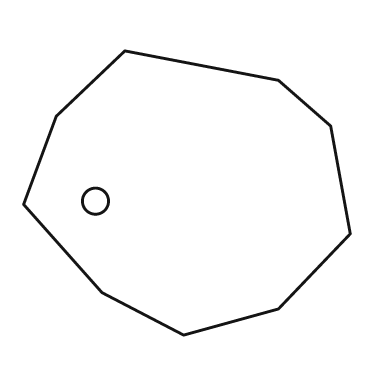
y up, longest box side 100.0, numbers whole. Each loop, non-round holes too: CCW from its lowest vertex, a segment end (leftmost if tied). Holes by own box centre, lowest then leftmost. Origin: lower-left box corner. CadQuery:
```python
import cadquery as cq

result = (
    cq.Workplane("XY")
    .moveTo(49.0, 0.0)
    .lineTo(78.0, 8.0)
    .lineTo(100.0, 31.0)
    .lineTo(94.0, 64.0)
    .lineTo(78.0, 78.0)
    .lineTo(31.0, 87.0)
    .lineTo(10.0, 67.0)
    .lineTo(0.0, 40.0)
    .lineTo(24.0, 13.0)
    .close()
    .moveTo(22.0, 41.0)
    .circle(4.0)
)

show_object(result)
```